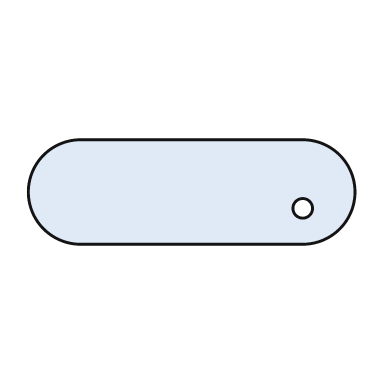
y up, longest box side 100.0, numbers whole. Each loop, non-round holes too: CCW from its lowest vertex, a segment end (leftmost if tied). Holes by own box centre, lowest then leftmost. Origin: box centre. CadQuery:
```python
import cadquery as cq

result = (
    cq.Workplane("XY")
    .moveTo(-34.0, -16.0)
    .lineTo(34.0, -16.0)
    .threePointArc((50.0, 0.0), (34.0, 16.0))
    .lineTo(-34.0, 16.0)
    .threePointArc((-50.0, 0.0), (-34.0, -16.0))
    .close()
    .moveTo(34.0, -5.0)
    .circle(3.0)
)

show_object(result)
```